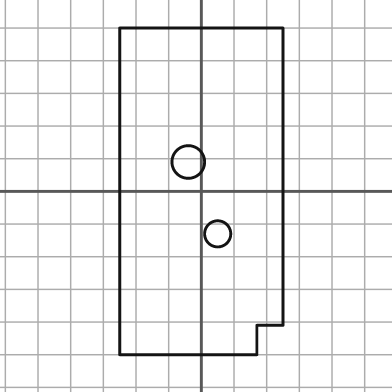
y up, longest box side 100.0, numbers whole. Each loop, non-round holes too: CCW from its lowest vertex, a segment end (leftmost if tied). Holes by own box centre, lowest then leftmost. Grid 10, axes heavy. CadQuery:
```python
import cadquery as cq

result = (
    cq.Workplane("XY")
    .moveTo(-25.0, -50.0)
    .lineTo(17.0, -50.0)
    .lineTo(17.0, -41.0)
    .lineTo(25.0, -41.0)
    .lineTo(25.0, 50.0)
    .lineTo(-25.0, 50.0)
    .close()
    .moveTo(5.0, -13.0)
    .circle(4.0)
    .moveTo(-4.0, 9.0)
    .circle(5.0)
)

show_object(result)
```